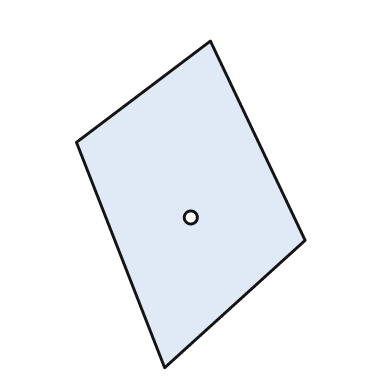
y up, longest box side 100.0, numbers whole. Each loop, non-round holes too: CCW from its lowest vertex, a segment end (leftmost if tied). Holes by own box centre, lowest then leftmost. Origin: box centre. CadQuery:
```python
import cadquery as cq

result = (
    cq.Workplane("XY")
    .moveTo(-8.0, -50.0)
    .lineTo(35.0, -11.0)
    .lineTo(6.0, 50.0)
    .lineTo(-35.0, 19.0)
    .close()
    .moveTo(0.0, -4.0)
    .circle(2.0)
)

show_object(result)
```